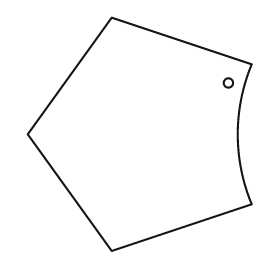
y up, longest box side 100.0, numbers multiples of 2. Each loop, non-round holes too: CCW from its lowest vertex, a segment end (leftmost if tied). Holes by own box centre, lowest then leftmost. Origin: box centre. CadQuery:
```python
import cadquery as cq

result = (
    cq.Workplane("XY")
    .moveTo(-12.0, -50.0)
    .lineTo(48.0, -30.0)
    .threePointArc((42.0, 0.0), (48.0, 30.0))
    .lineTo(-12.0, 50.0)
    .lineTo(-48.0, 0.0)
    .close()
    .moveTo(38.0, 22.0)
    .circle(2.0)
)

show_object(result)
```